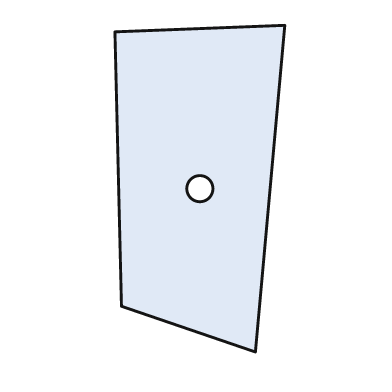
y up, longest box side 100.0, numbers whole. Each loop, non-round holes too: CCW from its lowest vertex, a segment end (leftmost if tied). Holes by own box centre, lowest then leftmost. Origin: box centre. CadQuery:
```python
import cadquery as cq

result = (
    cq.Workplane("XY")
    .moveTo(17.0, -50.0)
    .lineTo(26.0, 50.0)
    .lineTo(-26.0, 48.0)
    .lineTo(-24.0, -36.0)
    .close()
    .moveTo(0.0, 0.0)
    .circle(4.0)
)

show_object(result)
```